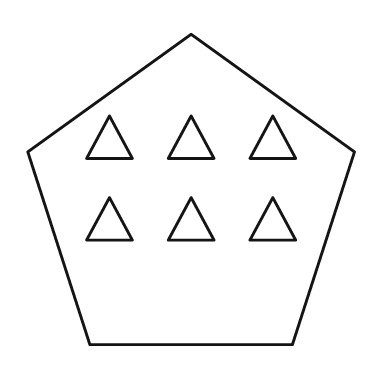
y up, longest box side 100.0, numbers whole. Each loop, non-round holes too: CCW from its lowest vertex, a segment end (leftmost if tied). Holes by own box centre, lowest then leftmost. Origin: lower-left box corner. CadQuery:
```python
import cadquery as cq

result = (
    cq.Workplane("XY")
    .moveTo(19.0, 0.0)
    .lineTo(81.0, 0.0)
    .lineTo(100.0, 59.0)
    .lineTo(50.0, 95.0)
    .lineTo(0.0, 59.0)
    .close()
    .moveTo(18.0, 32.0)
    .lineTo(32.0, 32.0)
    .lineTo(25.0, 45.0)
    .close()
    .moveTo(43.0, 32.0)
    .lineTo(57.0, 32.0)
    .lineTo(50.0, 45.0)
    .close()
    .moveTo(68.0, 32.0)
    .lineTo(82.0, 32.0)
    .lineTo(75.0, 45.0)
    .close()
    .moveTo(18.0, 57.0)
    .lineTo(32.0, 57.0)
    .lineTo(25.0, 70.0)
    .close()
    .moveTo(43.0, 57.0)
    .lineTo(57.0, 57.0)
    .lineTo(50.0, 70.0)
    .close()
    .moveTo(68.0, 57.0)
    .lineTo(82.0, 57.0)
    .lineTo(75.0, 70.0)
    .close()
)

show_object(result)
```